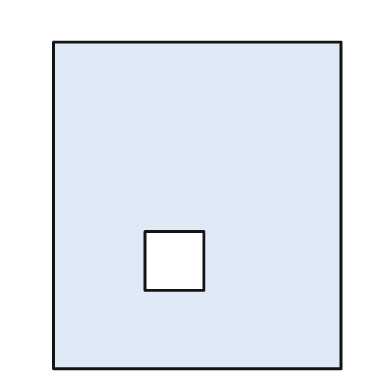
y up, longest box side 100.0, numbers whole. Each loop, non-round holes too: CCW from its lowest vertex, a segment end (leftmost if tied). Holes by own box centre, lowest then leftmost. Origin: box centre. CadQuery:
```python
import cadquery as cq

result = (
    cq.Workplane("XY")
    .moveTo(-44.0, -50.0)
    .lineTo(44.0, -50.0)
    .lineTo(44.0, 50.0)
    .lineTo(-44.0, 50.0)
    .close()
    .moveTo(-16.0, -26.0)
    .lineTo(2.0, -26.0)
    .lineTo(2.0, -8.0)
    .lineTo(-16.0, -8.0)
    .close()
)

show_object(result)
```